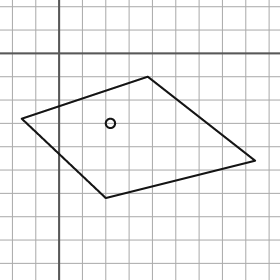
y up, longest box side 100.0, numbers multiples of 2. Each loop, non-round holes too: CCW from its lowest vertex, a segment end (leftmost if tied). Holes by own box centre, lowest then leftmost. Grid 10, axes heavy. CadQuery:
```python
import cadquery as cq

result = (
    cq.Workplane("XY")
    .moveTo(20.0, -62.0)
    .lineTo(84.0, -46.0)
    .lineTo(38.0, -10.0)
    .lineTo(-16.0, -28.0)
    .close()
    .moveTo(22.0, -30.0)
    .circle(2.0)
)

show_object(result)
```